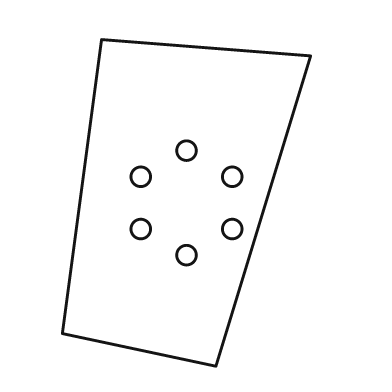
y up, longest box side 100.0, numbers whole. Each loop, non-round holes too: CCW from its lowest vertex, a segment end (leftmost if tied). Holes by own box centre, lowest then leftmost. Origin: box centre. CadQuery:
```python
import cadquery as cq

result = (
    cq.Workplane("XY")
    .moveTo(9.0, -50.0)
    .lineTo(38.0, 45.0)
    .lineTo(-26.0, 50.0)
    .lineTo(-38.0, -40.0)
    .close()
    .moveTo(0.0, -16.0)
    .circle(3.0)
    .moveTo(-14.0, -8.0)
    .circle(3.0)
    .moveTo(14.0, -8.0)
    .circle(3.0)
    .moveTo(-14.0, 8.0)
    .circle(3.0)
    .moveTo(14.0, 8.0)
    .circle(3.0)
    .moveTo(0.0, 16.0)
    .circle(3.0)
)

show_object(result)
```